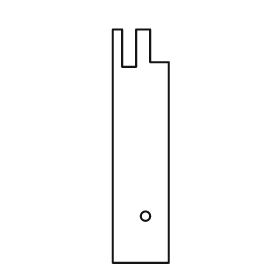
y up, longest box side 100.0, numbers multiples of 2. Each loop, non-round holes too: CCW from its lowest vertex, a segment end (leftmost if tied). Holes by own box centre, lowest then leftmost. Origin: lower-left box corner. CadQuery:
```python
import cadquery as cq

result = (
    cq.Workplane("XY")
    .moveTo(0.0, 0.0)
    .lineTo(24.0, 0.0)
    .lineTo(24.0, 86.0)
    .lineTo(16.0, 86.0)
    .lineTo(16.0, 100.0)
    .lineTo(10.0, 100.0)
    .lineTo(10.0, 84.0)
    .lineTo(4.0, 84.0)
    .lineTo(4.0, 100.0)
    .lineTo(0.0, 100.0)
    .close()
    .moveTo(14.0, 20.0)
    .circle(2.0)
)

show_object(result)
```